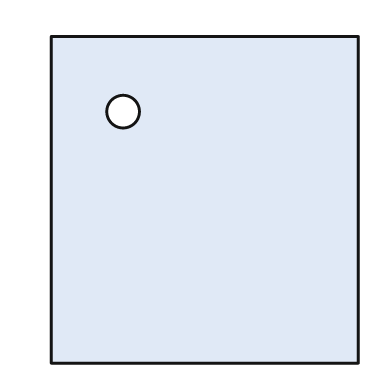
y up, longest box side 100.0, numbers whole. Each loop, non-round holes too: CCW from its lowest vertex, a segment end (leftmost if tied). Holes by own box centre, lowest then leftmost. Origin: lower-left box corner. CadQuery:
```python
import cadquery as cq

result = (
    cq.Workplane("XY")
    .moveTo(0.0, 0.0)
    .lineTo(94.0, 0.0)
    .lineTo(94.0, 100.0)
    .lineTo(0.0, 100.0)
    .close()
    .moveTo(22.0, 77.0)
    .circle(5.0)
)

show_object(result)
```